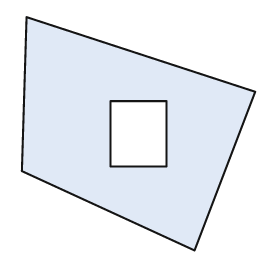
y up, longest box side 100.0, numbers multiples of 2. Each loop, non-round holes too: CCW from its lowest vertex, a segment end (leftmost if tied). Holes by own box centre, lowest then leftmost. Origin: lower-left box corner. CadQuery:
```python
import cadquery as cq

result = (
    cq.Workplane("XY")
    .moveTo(74.0, 0.0)
    .lineTo(100.0, 68.0)
    .lineTo(2.0, 100.0)
    .lineTo(0.0, 34.0)
    .close()
    .moveTo(38.0, 36.0)
    .lineTo(62.0, 36.0)
    .lineTo(62.0, 64.0)
    .lineTo(38.0, 64.0)
    .close()
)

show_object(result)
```